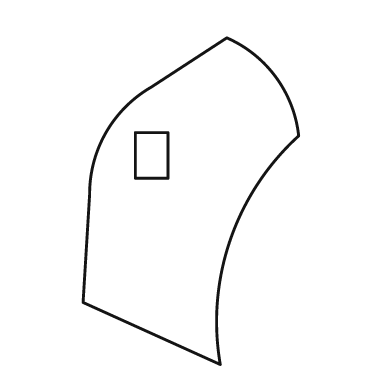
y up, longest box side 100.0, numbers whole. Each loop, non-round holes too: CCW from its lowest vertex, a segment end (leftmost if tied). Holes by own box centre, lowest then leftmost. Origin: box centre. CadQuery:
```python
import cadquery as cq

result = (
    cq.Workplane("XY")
    .moveTo(9.0, -50.0)
    .threePointArc((12.0, -12.0), (33.0, 20.0))
    .threePointArc((26.0, 38.0), (11.0, 50.0))
    .lineTo(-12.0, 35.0)
    .threePointArc((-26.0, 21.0), (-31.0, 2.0))
    .lineTo(-33.0, -31.0)
    .close()
    .moveTo(-17.0, 7.0)
    .lineTo(-7.0, 7.0)
    .lineTo(-7.0, 21.0)
    .lineTo(-17.0, 21.0)
    .close()
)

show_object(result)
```